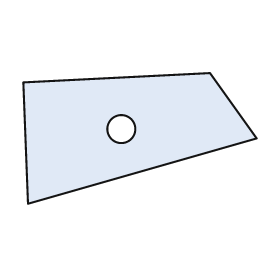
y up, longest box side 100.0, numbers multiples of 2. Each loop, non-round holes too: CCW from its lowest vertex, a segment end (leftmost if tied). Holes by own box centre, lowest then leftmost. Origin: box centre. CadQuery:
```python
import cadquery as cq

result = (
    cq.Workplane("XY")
    .moveTo(-48.0, -28.0)
    .lineTo(50.0, 0.0)
    .lineTo(30.0, 28.0)
    .lineTo(-50.0, 24.0)
    .close()
    .moveTo(-8.0, 4.0)
    .circle(6.0)
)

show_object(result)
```